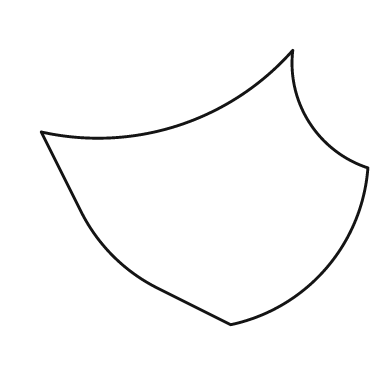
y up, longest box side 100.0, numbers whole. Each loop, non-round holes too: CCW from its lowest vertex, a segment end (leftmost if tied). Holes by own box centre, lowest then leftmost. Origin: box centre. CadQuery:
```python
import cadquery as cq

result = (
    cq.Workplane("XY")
    .moveTo(8.0, -42.0)
    .threePointArc((37.0, -25.0), (50.0, 6.0))
    .threePointArc((32.0, 20.0), (27.0, 42.0))
    .threePointArc((-8.0, 19.0), (-50.0, 17.0))
    .lineTo(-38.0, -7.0)
    .threePointArc((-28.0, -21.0), (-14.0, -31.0))
    .close()
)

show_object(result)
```